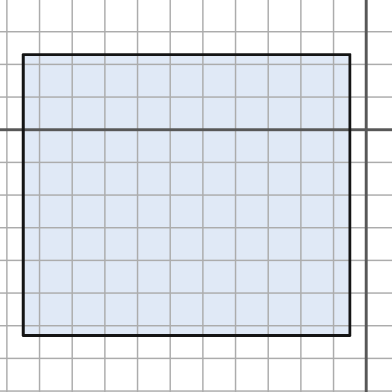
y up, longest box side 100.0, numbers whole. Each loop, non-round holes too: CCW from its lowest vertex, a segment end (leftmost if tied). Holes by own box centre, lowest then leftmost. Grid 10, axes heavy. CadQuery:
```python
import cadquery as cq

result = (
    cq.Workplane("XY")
    .moveTo(-105.0, -63.0)
    .lineTo(-5.0, -63.0)
    .lineTo(-5.0, 23.0)
    .lineTo(-105.0, 23.0)
    .close()
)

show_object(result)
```